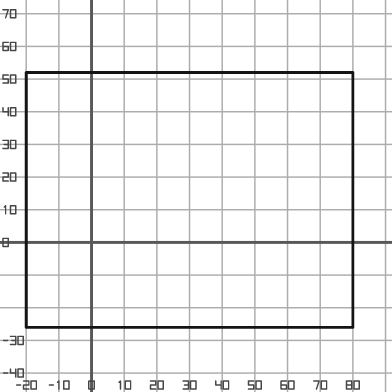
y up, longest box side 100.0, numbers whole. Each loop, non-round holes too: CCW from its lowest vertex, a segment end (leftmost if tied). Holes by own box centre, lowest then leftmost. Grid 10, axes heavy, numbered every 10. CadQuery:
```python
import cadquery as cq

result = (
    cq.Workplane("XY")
    .moveTo(-20.0, -26.0)
    .lineTo(80.0, -26.0)
    .lineTo(80.0, 52.0)
    .lineTo(-20.0, 52.0)
    .close()
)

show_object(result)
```